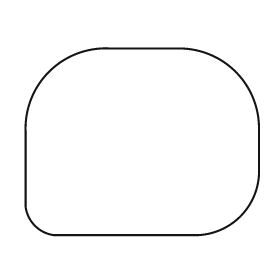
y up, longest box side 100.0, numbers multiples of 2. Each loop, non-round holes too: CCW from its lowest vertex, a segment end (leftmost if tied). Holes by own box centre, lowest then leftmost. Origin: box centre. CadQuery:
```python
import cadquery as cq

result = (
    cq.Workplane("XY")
    .moveTo(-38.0, -40.0)
    .lineTo(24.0, -40.0)
    .threePointArc((42.0, -32.0), (50.0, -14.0))
    .lineTo(50.0, 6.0)
    .threePointArc((40.0, 30.0), (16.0, 40.0))
    .lineTo(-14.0, 40.0)
    .threePointArc((-40.0, 30.0), (-50.0, 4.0))
    .lineTo(-50.0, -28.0)
    .threePointArc((-46.0, -36.0), (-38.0, -40.0))
    .close()
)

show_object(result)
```